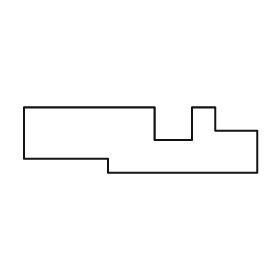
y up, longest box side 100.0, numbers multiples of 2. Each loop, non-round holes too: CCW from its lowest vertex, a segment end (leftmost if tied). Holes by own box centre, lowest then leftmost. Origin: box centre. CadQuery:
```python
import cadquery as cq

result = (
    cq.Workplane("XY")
    .moveTo(-14.0, -14.0)
    .lineTo(50.0, -14.0)
    .lineTo(50.0, 4.0)
    .lineTo(32.0, 4.0)
    .lineTo(32.0, 14.0)
    .lineTo(22.0, 14.0)
    .lineTo(22.0, 0.0)
    .lineTo(6.0, 0.0)
    .lineTo(6.0, 14.0)
    .lineTo(-50.0, 14.0)
    .lineTo(-50.0, -8.0)
    .lineTo(-14.0, -8.0)
    .close()
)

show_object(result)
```